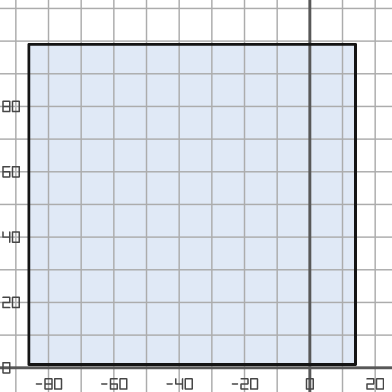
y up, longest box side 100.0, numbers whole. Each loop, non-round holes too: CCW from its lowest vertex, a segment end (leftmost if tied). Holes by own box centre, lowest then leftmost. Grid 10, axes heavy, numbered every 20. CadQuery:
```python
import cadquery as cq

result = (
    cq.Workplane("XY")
    .moveTo(-86.0, 1.0)
    .lineTo(14.0, 1.0)
    .lineTo(14.0, 99.0)
    .lineTo(-86.0, 99.0)
    .close()
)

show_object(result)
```